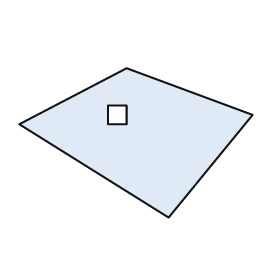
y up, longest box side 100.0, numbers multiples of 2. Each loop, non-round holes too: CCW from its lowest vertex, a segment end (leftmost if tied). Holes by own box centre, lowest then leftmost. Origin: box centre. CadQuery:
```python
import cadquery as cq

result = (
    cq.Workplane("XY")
    .moveTo(14.0, -32.0)
    .lineTo(50.0, 12.0)
    .lineTo(-4.0, 32.0)
    .lineTo(-50.0, 8.0)
    .close()
    .moveTo(-12.0, 8.0)
    .lineTo(-4.0, 8.0)
    .lineTo(-4.0, 16.0)
    .lineTo(-12.0, 16.0)
    .close()
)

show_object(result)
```